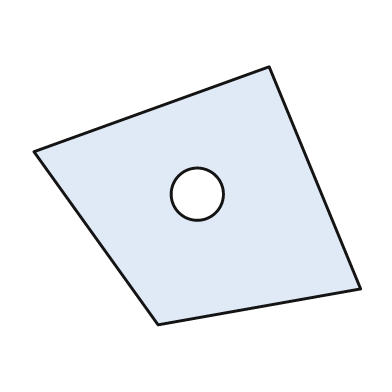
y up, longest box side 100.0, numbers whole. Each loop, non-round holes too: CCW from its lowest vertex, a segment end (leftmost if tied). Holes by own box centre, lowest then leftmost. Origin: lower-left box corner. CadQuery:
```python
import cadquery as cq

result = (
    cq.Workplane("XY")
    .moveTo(38.0, 0.0)
    .lineTo(100.0, 11.0)
    .lineTo(72.0, 79.0)
    .lineTo(0.0, 53.0)
    .close()
    .moveTo(50.0, 40.0)
    .circle(8.0)
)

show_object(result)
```